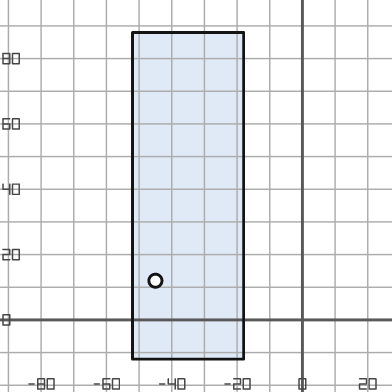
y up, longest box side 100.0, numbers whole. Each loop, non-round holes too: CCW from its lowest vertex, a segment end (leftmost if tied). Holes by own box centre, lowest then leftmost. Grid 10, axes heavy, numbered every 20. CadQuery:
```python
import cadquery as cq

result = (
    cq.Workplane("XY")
    .moveTo(-52.0, -12.0)
    .lineTo(-18.0, -12.0)
    .lineTo(-18.0, 88.0)
    .lineTo(-52.0, 88.0)
    .close()
    .moveTo(-45.0, 12.0)
    .circle(2.0)
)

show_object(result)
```